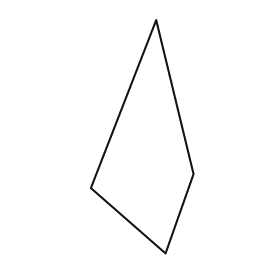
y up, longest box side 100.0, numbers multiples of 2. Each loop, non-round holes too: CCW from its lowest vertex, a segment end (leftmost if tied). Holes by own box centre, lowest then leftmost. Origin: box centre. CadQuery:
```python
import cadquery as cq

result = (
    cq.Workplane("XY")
    .moveTo(10.0, -50.0)
    .lineTo(22.0, -16.0)
    .lineTo(6.0, 50.0)
    .lineTo(-22.0, -22.0)
    .close()
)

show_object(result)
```